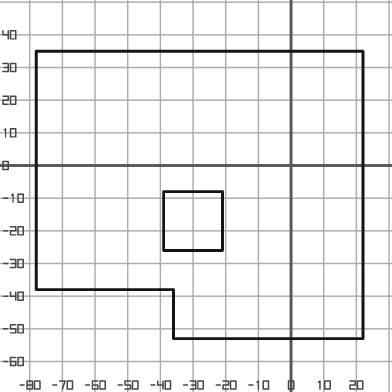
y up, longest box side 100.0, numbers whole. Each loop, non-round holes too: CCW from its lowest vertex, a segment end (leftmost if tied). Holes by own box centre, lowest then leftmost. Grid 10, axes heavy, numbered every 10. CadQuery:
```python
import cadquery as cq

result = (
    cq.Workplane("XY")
    .moveTo(-36.0, -53.0)
    .lineTo(22.0, -53.0)
    .lineTo(22.0, 35.0)
    .lineTo(-78.0, 35.0)
    .lineTo(-78.0, -38.0)
    .lineTo(-36.0, -38.0)
    .close()
    .moveTo(-39.0, -26.0)
    .lineTo(-21.0, -26.0)
    .lineTo(-21.0, -8.0)
    .lineTo(-39.0, -8.0)
    .close()
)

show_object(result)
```